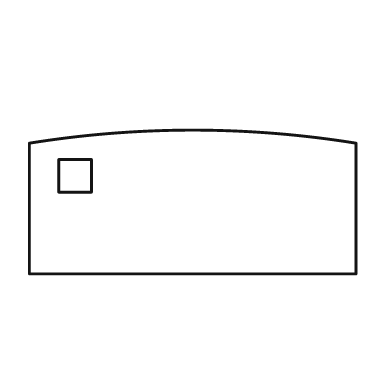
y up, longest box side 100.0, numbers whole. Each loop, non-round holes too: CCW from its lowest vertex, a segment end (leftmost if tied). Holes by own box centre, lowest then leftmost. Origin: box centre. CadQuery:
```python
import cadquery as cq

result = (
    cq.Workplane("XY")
    .moveTo(-50.0, -22.0)
    .lineTo(50.0, -22.0)
    .lineTo(50.0, 18.0)
    .threePointArc((0.0, 22.0), (-50.0, 18.0))
    .close()
    .moveTo(-41.0, 3.0)
    .lineTo(-31.0, 3.0)
    .lineTo(-31.0, 13.0)
    .lineTo(-41.0, 13.0)
    .close()
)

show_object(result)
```